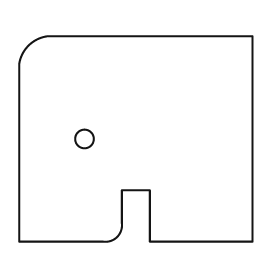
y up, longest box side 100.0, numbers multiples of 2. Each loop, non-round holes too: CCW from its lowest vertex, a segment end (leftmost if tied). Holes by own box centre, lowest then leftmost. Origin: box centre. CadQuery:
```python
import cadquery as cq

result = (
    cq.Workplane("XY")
    .moveTo(-50.0, -44.0)
    .lineTo(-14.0, -44.0)
    .threePointArc((-8.0, -42.0), (-6.0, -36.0))
    .lineTo(-6.0, -22.0)
    .lineTo(6.0, -22.0)
    .lineTo(6.0, -44.0)
    .lineTo(50.0, -44.0)
    .lineTo(50.0, 44.0)
    .lineTo(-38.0, 44.0)
    .threePointArc((-46.0, 40.0), (-50.0, 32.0))
    .close()
    .moveTo(-22.0, 0.0)
    .circle(4.0)
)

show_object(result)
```